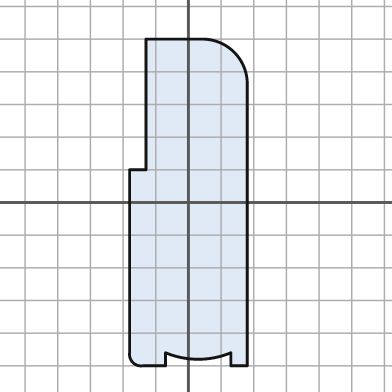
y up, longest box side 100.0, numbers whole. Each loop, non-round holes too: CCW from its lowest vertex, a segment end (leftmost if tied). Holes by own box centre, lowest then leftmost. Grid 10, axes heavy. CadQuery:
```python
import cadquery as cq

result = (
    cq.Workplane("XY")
    .moveTo(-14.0, -50.0)
    .lineTo(-7.0, -50.0)
    .lineTo(-7.0, -46.0)
    .threePointArc((3.0, -48.0), (13.0, -46.0))
    .lineTo(13.0, -50.0)
    .lineTo(18.0, -50.0)
    .lineTo(18.0, 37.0)
    .threePointArc((14.0, 46.0), (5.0, 50.0))
    .lineTo(-13.0, 50.0)
    .lineTo(-13.0, 10.0)
    .lineTo(-18.0, 10.0)
    .lineTo(-18.0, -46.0)
    .threePointArc((-17.0, -49.0), (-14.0, -50.0))
    .close()
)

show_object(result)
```